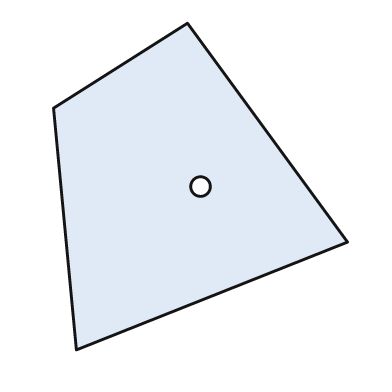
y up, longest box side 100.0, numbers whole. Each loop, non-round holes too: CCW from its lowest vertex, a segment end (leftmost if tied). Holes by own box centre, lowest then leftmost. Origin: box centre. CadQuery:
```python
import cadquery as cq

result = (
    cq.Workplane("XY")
    .moveTo(-38.0, -50.0)
    .lineTo(45.0, -17.0)
    .lineTo(-4.0, 50.0)
    .lineTo(-45.0, 24.0)
    .close()
    .moveTo(0.0, 0.0)
    .circle(3.0)
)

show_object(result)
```